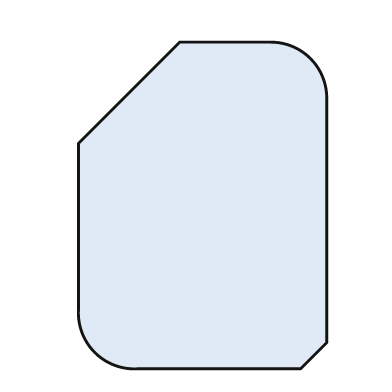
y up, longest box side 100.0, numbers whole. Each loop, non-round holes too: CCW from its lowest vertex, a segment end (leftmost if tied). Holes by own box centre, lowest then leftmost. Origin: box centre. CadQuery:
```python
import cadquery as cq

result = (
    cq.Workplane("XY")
    .moveTo(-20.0, -50.0)
    .lineTo(30.0, -50.0)
    .lineTo(38.0, -42.0)
    .lineTo(38.0, 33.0)
    .threePointArc((33.0, 45.0), (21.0, 50.0))
    .lineTo(-7.0, 50.0)
    .lineTo(-38.0, 19.0)
    .lineTo(-38.0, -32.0)
    .threePointArc((-33.0, -45.0), (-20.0, -50.0))
    .close()
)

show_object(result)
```